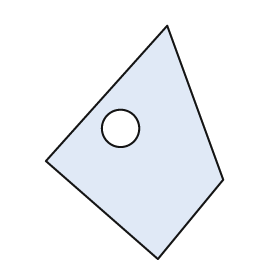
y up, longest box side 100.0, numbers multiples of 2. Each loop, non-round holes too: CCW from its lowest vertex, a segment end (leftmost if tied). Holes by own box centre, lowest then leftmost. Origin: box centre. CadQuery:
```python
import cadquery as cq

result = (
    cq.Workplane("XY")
    .moveTo(10.0, -50.0)
    .lineTo(38.0, -16.0)
    .lineTo(14.0, 50.0)
    .lineTo(-38.0, -8.0)
    .close()
    .moveTo(-6.0, 6.0)
    .circle(8.0)
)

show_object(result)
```